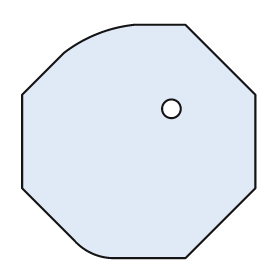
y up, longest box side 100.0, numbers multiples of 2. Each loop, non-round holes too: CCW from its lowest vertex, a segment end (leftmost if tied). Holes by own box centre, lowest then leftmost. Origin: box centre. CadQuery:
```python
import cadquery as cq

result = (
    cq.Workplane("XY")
    .moveTo(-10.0, -50.0)
    .lineTo(20.0, -50.0)
    .lineTo(50.0, -20.0)
    .lineTo(50.0, 20.0)
    .lineTo(20.0, 50.0)
    .lineTo(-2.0, 50.0)
    .threePointArc((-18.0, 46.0), (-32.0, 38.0))
    .lineTo(-50.0, 20.0)
    .lineTo(-50.0, -20.0)
    .lineTo(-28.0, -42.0)
    .threePointArc((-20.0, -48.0), (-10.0, -50.0))
    .close()
    .moveTo(14.0, 14.0)
    .circle(4.0)
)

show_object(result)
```